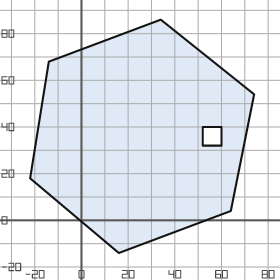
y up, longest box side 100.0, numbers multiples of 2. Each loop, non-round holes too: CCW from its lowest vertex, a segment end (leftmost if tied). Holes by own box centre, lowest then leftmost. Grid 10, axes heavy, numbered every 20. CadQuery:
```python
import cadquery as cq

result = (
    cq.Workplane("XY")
    .moveTo(16.0, -14.0)
    .lineTo(64.0, 4.0)
    .lineTo(74.0, 54.0)
    .lineTo(34.0, 86.0)
    .lineTo(-14.0, 68.0)
    .lineTo(-22.0, 18.0)
    .close()
    .moveTo(52.0, 32.0)
    .lineTo(60.0, 32.0)
    .lineTo(60.0, 40.0)
    .lineTo(52.0, 40.0)
    .close()
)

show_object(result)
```